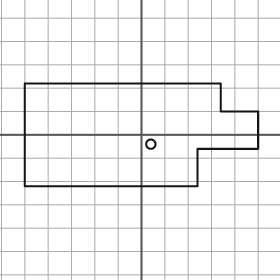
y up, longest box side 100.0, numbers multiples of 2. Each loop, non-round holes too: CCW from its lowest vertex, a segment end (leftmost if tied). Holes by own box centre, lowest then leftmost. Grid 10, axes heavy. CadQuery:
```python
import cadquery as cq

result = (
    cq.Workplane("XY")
    .moveTo(-50.0, -22.0)
    .lineTo(24.0, -22.0)
    .lineTo(24.0, -6.0)
    .lineTo(50.0, -6.0)
    .lineTo(50.0, 10.0)
    .lineTo(34.0, 10.0)
    .lineTo(34.0, 22.0)
    .lineTo(-50.0, 22.0)
    .close()
    .moveTo(4.0, -4.0)
    .circle(2.0)
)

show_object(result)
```